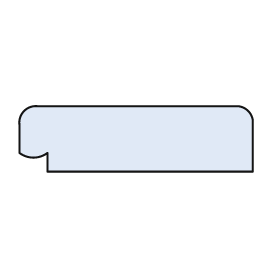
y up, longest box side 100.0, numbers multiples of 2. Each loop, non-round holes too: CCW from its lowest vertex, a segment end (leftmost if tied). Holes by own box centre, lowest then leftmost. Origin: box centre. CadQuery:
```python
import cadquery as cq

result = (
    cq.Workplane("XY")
    .moveTo(-38.0, -14.0)
    .lineTo(50.0, -14.0)
    .lineTo(50.0, 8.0)
    .threePointArc((48.0, 12.0), (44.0, 14.0))
    .lineTo(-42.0, 14.0)
    .threePointArc((-48.0, 12.0), (-50.0, 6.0))
    .lineTo(-50.0, -6.0)
    .threePointArc((-44.0, -8.0), (-38.0, -6.0))
    .close()
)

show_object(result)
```